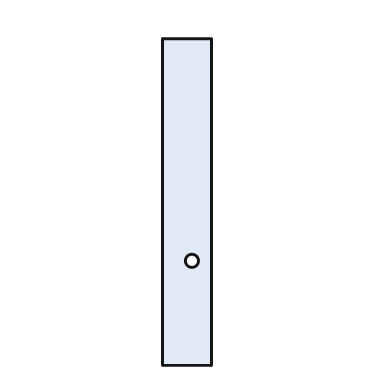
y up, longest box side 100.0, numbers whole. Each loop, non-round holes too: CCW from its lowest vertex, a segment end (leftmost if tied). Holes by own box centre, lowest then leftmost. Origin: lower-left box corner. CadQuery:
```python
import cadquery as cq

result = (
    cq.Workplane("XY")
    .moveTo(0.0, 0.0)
    .lineTo(15.0, 0.0)
    .lineTo(15.0, 100.0)
    .lineTo(0.0, 100.0)
    .close()
    .moveTo(9.0, 32.0)
    .circle(2.0)
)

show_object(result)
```